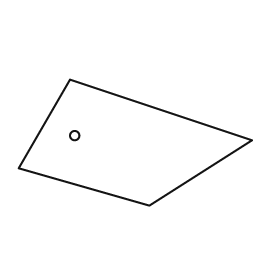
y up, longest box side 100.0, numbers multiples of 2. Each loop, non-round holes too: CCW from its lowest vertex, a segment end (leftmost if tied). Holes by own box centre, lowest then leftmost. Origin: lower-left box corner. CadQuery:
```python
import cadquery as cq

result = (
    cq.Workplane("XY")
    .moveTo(56.0, 0.0)
    .lineTo(100.0, 28.0)
    .lineTo(22.0, 54.0)
    .lineTo(0.0, 16.0)
    .close()
    .moveTo(24.0, 30.0)
    .circle(2.0)
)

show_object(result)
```